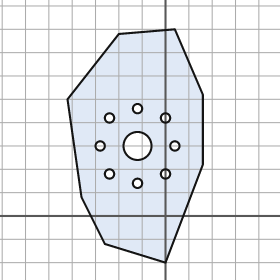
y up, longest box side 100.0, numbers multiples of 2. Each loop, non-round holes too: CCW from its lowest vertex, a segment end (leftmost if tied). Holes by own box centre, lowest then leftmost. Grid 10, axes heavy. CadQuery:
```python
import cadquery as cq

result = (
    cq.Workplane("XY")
    .moveTo(0.0, -20.0)
    .lineTo(16.0, 22.0)
    .lineTo(16.0, 52.0)
    .lineTo(4.0, 80.0)
    .lineTo(-20.0, 78.0)
    .lineTo(-42.0, 50.0)
    .lineTo(-36.0, 8.0)
    .lineTo(-26.0, -12.0)
    .close()
    .moveTo(-12.0, 14.0)
    .circle(2.0)
    .moveTo(-24.0, 18.0)
    .circle(2.0)
    .moveTo(0.0, 18.0)
    .circle(2.0)
    .moveTo(-28.0, 30.0)
    .circle(2.0)
    .moveTo(-12.0, 30.0)
    .circle(6.0)
    .moveTo(4.0, 30.0)
    .circle(2.0)
    .moveTo(-24.0, 42.0)
    .circle(2.0)
    .moveTo(0.0, 42.0)
    .circle(2.0)
    .moveTo(-12.0, 46.0)
    .circle(2.0)
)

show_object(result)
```